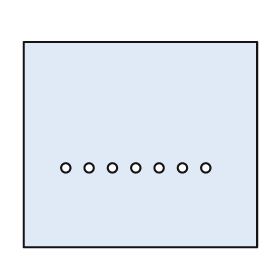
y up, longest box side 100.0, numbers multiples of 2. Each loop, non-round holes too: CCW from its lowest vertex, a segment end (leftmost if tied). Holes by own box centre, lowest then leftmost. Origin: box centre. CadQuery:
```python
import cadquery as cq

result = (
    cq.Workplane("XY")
    .moveTo(-50.0, -44.0)
    .lineTo(50.0, -44.0)
    .lineTo(50.0, 44.0)
    .lineTo(-50.0, 44.0)
    .close()
    .moveTo(-32.0, -10.0)
    .circle(2.0)
    .moveTo(-22.0, -10.0)
    .circle(2.0)
    .moveTo(-12.0, -10.0)
    .circle(2.0)
    .moveTo(-2.0, -10.0)
    .circle(2.0)
    .moveTo(8.0, -10.0)
    .circle(2.0)
    .moveTo(18.0, -10.0)
    .circle(2.0)
    .moveTo(28.0, -10.0)
    .circle(2.0)
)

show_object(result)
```